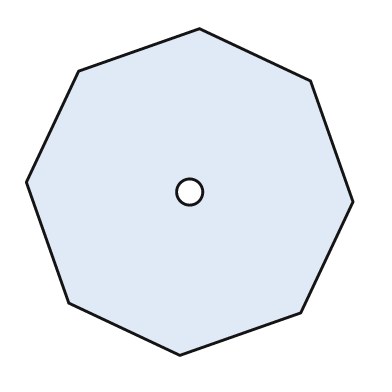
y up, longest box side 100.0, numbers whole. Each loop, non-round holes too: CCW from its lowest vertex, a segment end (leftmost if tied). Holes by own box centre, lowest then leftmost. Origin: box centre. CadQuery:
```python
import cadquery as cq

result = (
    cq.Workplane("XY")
    .moveTo(-3.0, -50.0)
    .lineTo(34.0, -37.0)
    .lineTo(50.0, -3.0)
    .lineTo(37.0, 34.0)
    .lineTo(3.0, 50.0)
    .lineTo(-34.0, 37.0)
    .lineTo(-50.0, 3.0)
    .lineTo(-37.0, -34.0)
    .close()
    .moveTo(0.0, 0.0)
    .circle(4.0)
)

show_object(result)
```